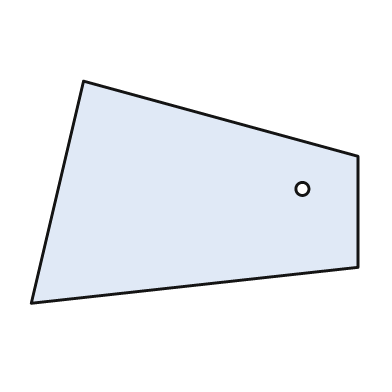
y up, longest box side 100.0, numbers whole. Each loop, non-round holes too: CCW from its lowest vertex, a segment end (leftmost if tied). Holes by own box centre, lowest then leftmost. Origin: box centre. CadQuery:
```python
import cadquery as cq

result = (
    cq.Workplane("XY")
    .moveTo(-50.0, -34.0)
    .lineTo(50.0, -23.0)
    .lineTo(50.0, 11.0)
    .lineTo(-34.0, 34.0)
    .close()
    .moveTo(33.0, 1.0)
    .circle(2.0)
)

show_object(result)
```